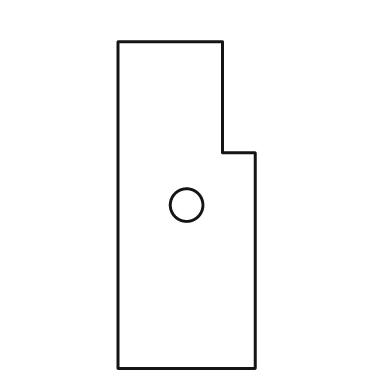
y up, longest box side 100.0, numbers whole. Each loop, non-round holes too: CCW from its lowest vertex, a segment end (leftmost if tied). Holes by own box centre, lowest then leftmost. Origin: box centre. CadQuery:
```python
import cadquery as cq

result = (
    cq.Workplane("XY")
    .moveTo(-21.0, -50.0)
    .lineTo(21.0, -50.0)
    .lineTo(21.0, 16.0)
    .lineTo(11.0, 16.0)
    .lineTo(11.0, 50.0)
    .lineTo(-21.0, 50.0)
    .close()
    .moveTo(0.0, 0.0)
    .circle(5.0)
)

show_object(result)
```